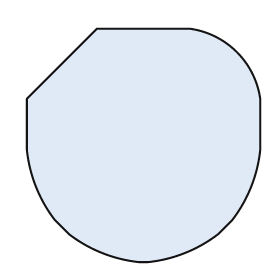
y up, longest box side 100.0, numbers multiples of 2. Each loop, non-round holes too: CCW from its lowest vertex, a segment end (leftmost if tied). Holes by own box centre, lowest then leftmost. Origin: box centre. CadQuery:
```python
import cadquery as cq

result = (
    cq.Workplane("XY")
    .moveTo(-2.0, -50.0)
    .lineTo(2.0, -50.0)
    .threePointArc((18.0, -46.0), (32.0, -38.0))
    .lineTo(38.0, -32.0)
    .threePointArc((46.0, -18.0), (50.0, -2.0))
    .lineTo(50.0, 20.0)
    .threePointArc((40.0, 40.0), (20.0, 50.0))
    .lineTo(-20.0, 50.0)
    .lineTo(-50.0, 20.0)
    .lineTo(-50.0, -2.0)
    .threePointArc((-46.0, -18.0), (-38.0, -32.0))
    .lineTo(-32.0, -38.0)
    .threePointArc((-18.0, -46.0), (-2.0, -50.0))
    .close()
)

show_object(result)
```